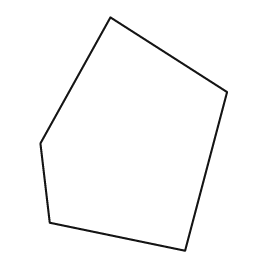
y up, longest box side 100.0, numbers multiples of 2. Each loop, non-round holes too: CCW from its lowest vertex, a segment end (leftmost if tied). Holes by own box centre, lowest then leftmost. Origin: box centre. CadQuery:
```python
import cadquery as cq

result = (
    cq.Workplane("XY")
    .moveTo(22.0, -50.0)
    .lineTo(40.0, 18.0)
    .lineTo(-10.0, 50.0)
    .lineTo(-40.0, -4.0)
    .lineTo(-36.0, -38.0)
    .close()
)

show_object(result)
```